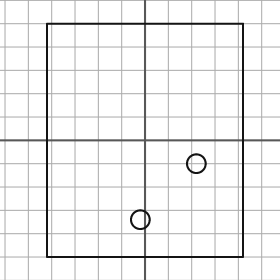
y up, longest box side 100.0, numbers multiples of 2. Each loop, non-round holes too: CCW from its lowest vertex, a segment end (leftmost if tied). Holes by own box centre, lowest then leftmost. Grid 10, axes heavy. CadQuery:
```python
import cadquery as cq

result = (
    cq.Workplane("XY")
    .moveTo(-42.0, -50.0)
    .lineTo(42.0, -50.0)
    .lineTo(42.0, 50.0)
    .lineTo(-42.0, 50.0)
    .close()
    .moveTo(-2.0, -34.0)
    .circle(4.0)
    .moveTo(22.0, -10.0)
    .circle(4.0)
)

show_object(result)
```